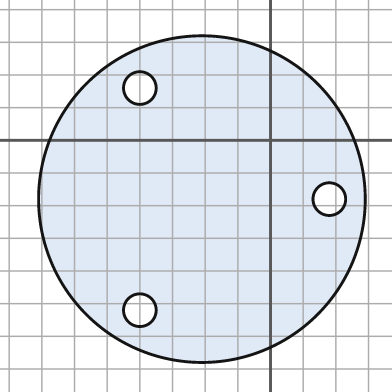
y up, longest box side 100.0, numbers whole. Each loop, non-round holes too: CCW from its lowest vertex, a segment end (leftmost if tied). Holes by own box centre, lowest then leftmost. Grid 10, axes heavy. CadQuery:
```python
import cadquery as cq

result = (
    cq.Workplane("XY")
    .moveTo(-21.0, -18.0)
    .circle(50.0)
    .moveTo(-40.0, -52.0)
    .circle(5.0)
    .moveTo(18.0, -18.0)
    .circle(5.0)
    .moveTo(-40.0, 16.0)
    .circle(5.0)
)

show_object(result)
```